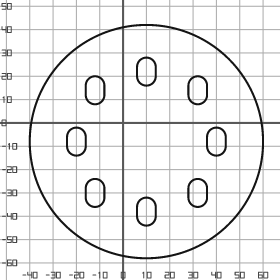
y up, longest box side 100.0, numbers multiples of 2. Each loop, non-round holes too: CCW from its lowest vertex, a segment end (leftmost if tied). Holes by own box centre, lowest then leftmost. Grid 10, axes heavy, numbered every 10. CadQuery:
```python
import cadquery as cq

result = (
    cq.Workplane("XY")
    .moveTo(10.0, -8.0)
    .circle(50.0)
    .moveTo(6.0, -40.0)
    .threePointArc((10.0, -44.0), (14.0, -40.0))
    .lineTo(14.0, -36.0)
    .threePointArc((10.0, -32.0), (6.0, -36.0))
    .close()
    .moveTo(-16.0, -32.0)
    .threePointArc((-12.0, -36.0), (-8.0, -32.0))
    .lineTo(-8.0, -28.0)
    .threePointArc((-12.0, -24.0), (-16.0, -28.0))
    .close()
    .moveTo(28.0, -32.0)
    .threePointArc((32.0, -36.0), (36.0, -32.0))
    .lineTo(36.0, -28.0)
    .threePointArc((32.0, -24.0), (28.0, -28.0))
    .close()
    .moveTo(-24.0, -10.0)
    .threePointArc((-20.0, -14.0), (-16.0, -10.0))
    .lineTo(-16.0, -6.0)
    .threePointArc((-20.0, -2.0), (-24.0, -6.0))
    .close()
    .moveTo(36.0, -10.0)
    .threePointArc((40.0, -14.0), (44.0, -10.0))
    .lineTo(44.0, -6.0)
    .threePointArc((40.0, -2.0), (36.0, -6.0))
    .close()
    .moveTo(-16.0, 12.0)
    .threePointArc((-12.0, 8.0), (-8.0, 12.0))
    .lineTo(-8.0, 16.0)
    .threePointArc((-12.0, 20.0), (-16.0, 16.0))
    .close()
    .moveTo(28.0, 12.0)
    .threePointArc((32.0, 8.0), (36.0, 12.0))
    .lineTo(36.0, 16.0)
    .threePointArc((32.0, 20.0), (28.0, 16.0))
    .close()
    .moveTo(6.0, 20.0)
    .threePointArc((10.0, 16.0), (14.0, 20.0))
    .lineTo(14.0, 24.0)
    .threePointArc((10.0, 28.0), (6.0, 24.0))
    .close()
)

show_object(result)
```